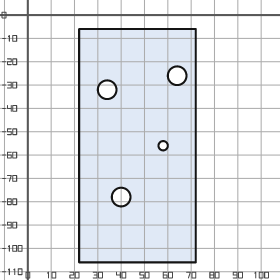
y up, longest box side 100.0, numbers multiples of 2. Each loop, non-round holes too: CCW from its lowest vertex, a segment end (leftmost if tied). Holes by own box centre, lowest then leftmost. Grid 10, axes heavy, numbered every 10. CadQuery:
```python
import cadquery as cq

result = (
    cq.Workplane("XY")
    .moveTo(22.0, -106.0)
    .lineTo(72.0, -106.0)
    .lineTo(72.0, -6.0)
    .lineTo(22.0, -6.0)
    .close()
    .moveTo(40.0, -78.0)
    .circle(4.0)
    .moveTo(58.0, -56.0)
    .circle(2.0)
    .moveTo(34.0, -32.0)
    .circle(4.0)
    .moveTo(64.0, -26.0)
    .circle(4.0)
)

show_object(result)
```